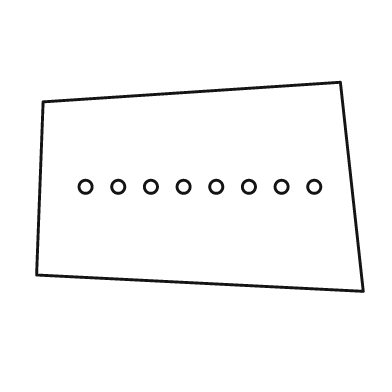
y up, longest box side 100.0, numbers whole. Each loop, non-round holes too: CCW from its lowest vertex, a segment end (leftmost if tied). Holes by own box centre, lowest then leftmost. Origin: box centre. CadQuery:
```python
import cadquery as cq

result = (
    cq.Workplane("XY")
    .moveTo(50.0, -32.0)
    .lineTo(43.0, 32.0)
    .lineTo(-48.0, 26.0)
    .lineTo(-50.0, -27.0)
    .close()
    .moveTo(-35.0, 0.0)
    .circle(2.0)
    .moveTo(-25.0, 0.0)
    .circle(2.0)
    .moveTo(-15.0, 0.0)
    .circle(2.0)
    .moveTo(-5.0, 0.0)
    .circle(2.0)
    .moveTo(5.0, 0.0)
    .circle(2.0)
    .moveTo(15.0, 0.0)
    .circle(2.0)
    .moveTo(25.0, 0.0)
    .circle(2.0)
    .moveTo(35.0, 0.0)
    .circle(2.0)
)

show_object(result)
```